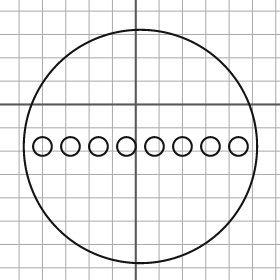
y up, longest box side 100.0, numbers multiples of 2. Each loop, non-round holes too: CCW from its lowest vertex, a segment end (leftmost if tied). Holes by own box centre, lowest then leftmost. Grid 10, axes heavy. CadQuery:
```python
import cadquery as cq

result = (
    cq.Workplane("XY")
    .moveTo(2.0, -18.0)
    .circle(50.0)
    .moveTo(-40.0, -18.0)
    .circle(4.0)
    .moveTo(-28.0, -18.0)
    .circle(4.0)
    .moveTo(-16.0, -18.0)
    .circle(4.0)
    .moveTo(-4.0, -18.0)
    .circle(4.0)
    .moveTo(8.0, -18.0)
    .circle(4.0)
    .moveTo(20.0, -18.0)
    .circle(4.0)
    .moveTo(32.0, -18.0)
    .circle(4.0)
    .moveTo(44.0, -18.0)
    .circle(4.0)
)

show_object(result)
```